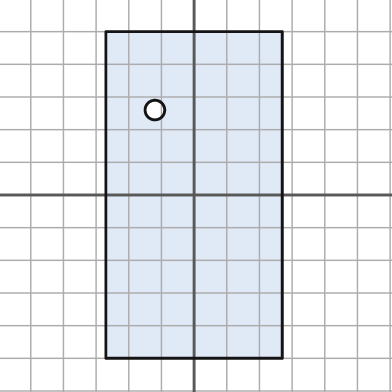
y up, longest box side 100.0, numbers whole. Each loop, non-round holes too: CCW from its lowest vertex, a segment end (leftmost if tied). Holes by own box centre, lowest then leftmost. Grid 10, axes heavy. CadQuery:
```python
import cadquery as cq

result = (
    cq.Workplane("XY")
    .moveTo(-27.0, -50.0)
    .lineTo(27.0, -50.0)
    .lineTo(27.0, 50.0)
    .lineTo(-27.0, 50.0)
    .close()
    .moveTo(-12.0, 26.0)
    .circle(3.0)
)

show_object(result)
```